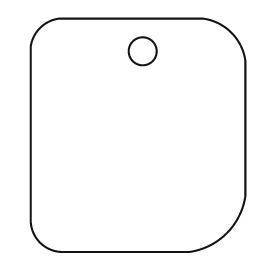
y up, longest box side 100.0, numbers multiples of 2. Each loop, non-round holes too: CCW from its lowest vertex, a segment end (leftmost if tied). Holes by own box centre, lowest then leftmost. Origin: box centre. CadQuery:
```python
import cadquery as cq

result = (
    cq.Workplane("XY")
    .moveTo(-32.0, -50.0)
    .lineTo(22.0, -50.0)
    .threePointArc((38.0, -42.0), (46.0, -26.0))
    .lineTo(46.0, 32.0)
    .threePointArc((40.0, 44.0), (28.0, 50.0))
    .lineTo(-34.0, 50.0)
    .threePointArc((-42.0, 46.0), (-46.0, 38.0))
    .lineTo(-46.0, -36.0)
    .threePointArc((-42.0, -46.0), (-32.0, -50.0))
    .close()
    .moveTo(2.0, 36.0)
    .circle(6.0)
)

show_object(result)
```